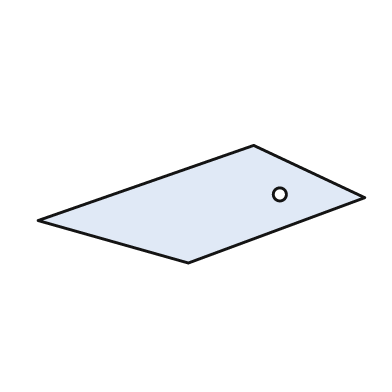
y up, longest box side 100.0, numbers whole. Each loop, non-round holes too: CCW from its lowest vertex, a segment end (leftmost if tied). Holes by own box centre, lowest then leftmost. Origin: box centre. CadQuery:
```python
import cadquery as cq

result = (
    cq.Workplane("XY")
    .moveTo(-4.0, -18.0)
    .lineTo(50.0, 2.0)
    .lineTo(16.0, 18.0)
    .lineTo(-50.0, -5.0)
    .close()
    .moveTo(24.0, 3.0)
    .circle(2.0)
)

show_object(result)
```